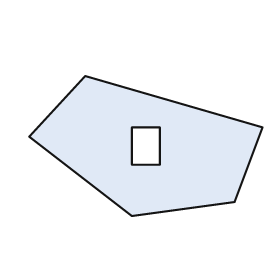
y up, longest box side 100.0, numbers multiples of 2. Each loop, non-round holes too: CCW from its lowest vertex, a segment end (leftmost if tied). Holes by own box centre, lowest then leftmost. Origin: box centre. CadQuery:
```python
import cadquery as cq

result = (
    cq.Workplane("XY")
    .moveTo(-6.0, -30.0)
    .lineTo(38.0, -24.0)
    .lineTo(50.0, 8.0)
    .lineTo(-26.0, 30.0)
    .lineTo(-50.0, 4.0)
    .close()
    .moveTo(-6.0, -8.0)
    .lineTo(6.0, -8.0)
    .lineTo(6.0, 8.0)
    .lineTo(-6.0, 8.0)
    .close()
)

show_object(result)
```